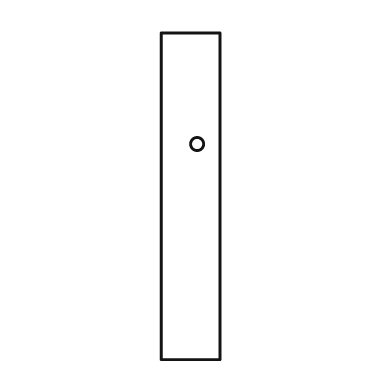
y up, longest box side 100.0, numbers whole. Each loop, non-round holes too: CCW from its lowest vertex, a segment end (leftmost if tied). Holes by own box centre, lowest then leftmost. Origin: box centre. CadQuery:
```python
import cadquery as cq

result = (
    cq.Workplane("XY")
    .moveTo(-9.0, -50.0)
    .lineTo(9.0, -50.0)
    .lineTo(9.0, 50.0)
    .lineTo(-9.0, 50.0)
    .close()
    .moveTo(2.0, 16.0)
    .circle(2.0)
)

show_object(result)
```